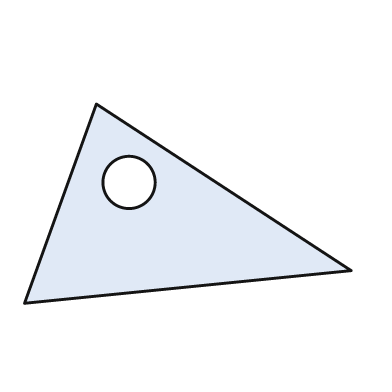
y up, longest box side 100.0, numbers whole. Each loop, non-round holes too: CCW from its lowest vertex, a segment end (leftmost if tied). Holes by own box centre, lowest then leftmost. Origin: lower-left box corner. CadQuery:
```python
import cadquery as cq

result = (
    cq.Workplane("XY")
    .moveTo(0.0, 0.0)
    .lineTo(100.0, 10.0)
    .lineTo(22.0, 61.0)
    .close()
    .moveTo(32.0, 37.0)
    .circle(8.0)
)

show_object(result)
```